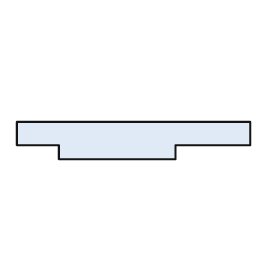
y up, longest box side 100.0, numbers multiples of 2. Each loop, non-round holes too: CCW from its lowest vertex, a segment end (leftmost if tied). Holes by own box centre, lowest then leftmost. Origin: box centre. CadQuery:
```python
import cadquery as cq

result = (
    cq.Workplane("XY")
    .moveTo(-32.0, -8.0)
    .lineTo(18.0, -8.0)
    .lineTo(18.0, -2.0)
    .lineTo(50.0, -2.0)
    .lineTo(50.0, 8.0)
    .lineTo(-50.0, 8.0)
    .lineTo(-50.0, -2.0)
    .lineTo(-32.0, -2.0)
    .close()
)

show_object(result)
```